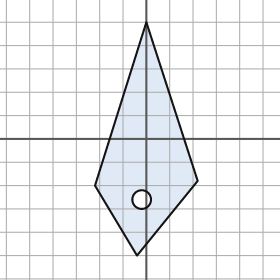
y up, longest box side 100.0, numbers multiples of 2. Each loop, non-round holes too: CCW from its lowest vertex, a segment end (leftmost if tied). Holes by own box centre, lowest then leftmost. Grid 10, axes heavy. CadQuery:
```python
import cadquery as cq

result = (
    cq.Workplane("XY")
    .moveTo(-4.0, -50.0)
    .lineTo(22.0, -18.0)
    .lineTo(0.0, 50.0)
    .lineTo(-22.0, -20.0)
    .close()
    .moveTo(-2.0, -26.0)
    .circle(4.0)
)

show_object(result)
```